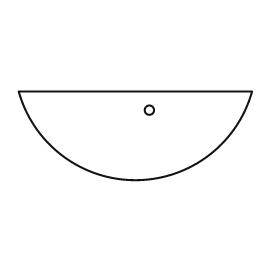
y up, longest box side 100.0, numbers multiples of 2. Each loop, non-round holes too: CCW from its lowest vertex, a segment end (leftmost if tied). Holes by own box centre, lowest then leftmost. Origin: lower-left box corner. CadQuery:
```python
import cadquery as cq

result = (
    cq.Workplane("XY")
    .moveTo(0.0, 38.0)
    .threePointArc((50.0, 0.0), (100.0, 38.0))
    .close()
    .moveTo(56.0, 30.0)
    .circle(2.0)
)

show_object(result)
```